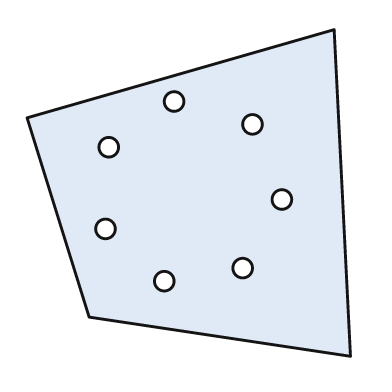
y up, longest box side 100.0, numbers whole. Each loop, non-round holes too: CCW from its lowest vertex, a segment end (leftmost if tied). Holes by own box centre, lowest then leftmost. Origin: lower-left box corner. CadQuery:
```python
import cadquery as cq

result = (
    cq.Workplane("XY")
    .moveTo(99.0, 0.0)
    .lineTo(94.0, 100.0)
    .lineTo(0.0, 73.0)
    .lineTo(19.0, 12.0)
    .close()
    .moveTo(42.0, 23.0)
    .circle(3.0)
    .moveTo(66.0, 27.0)
    .circle(3.0)
    .moveTo(24.0, 39.0)
    .circle(3.0)
    .moveTo(78.0, 48.0)
    .circle(3.0)
    .moveTo(25.0, 64.0)
    .circle(3.0)
    .moveTo(69.0, 71.0)
    .circle(3.0)
    .moveTo(45.0, 78.0)
    .circle(3.0)
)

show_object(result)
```